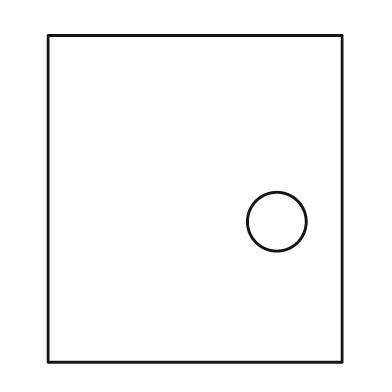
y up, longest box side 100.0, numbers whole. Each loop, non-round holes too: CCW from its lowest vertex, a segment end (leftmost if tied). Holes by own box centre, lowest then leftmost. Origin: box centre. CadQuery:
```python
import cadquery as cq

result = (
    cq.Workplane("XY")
    .moveTo(-45.0, -50.0)
    .lineTo(45.0, -50.0)
    .lineTo(45.0, 50.0)
    .lineTo(-45.0, 50.0)
    .close()
    .moveTo(25.0, -7.0)
    .circle(9.0)
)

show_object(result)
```